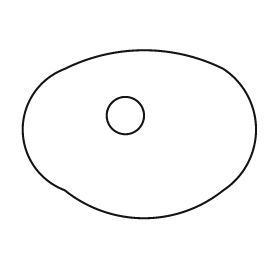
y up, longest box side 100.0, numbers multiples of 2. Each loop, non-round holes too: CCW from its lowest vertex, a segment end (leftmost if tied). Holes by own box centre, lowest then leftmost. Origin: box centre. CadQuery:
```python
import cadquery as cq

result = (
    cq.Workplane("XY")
    .moveTo(-32.0, -24.0)
    .threePointArc((2.0, -36.0), (36.0, -24.0))
    .threePointArc((50.0, 2.0), (36.0, 28.0))
    .threePointArc((2.0, 36.0), (-32.0, 28.0))
    .threePointArc((-50.0, 2.0), (-32.0, -24.0))
    .close()
    .moveTo(-6.0, 8.0)
    .circle(8.0)
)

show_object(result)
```